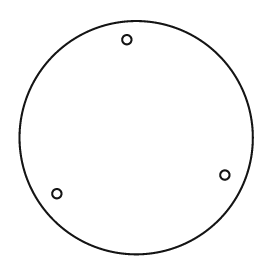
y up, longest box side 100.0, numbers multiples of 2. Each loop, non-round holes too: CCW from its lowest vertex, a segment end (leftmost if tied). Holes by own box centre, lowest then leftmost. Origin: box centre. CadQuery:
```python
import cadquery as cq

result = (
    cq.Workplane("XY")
    .moveTo(0.0, 0.0)
    .circle(50.0)
    .moveTo(-34.0, -24.0)
    .circle(2.0)
    .moveTo(38.0, -16.0)
    .circle(2.0)
    .moveTo(-4.0, 42.0)
    .circle(2.0)
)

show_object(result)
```